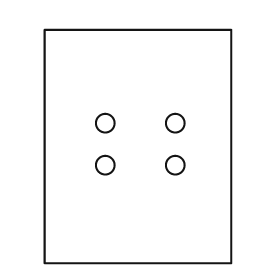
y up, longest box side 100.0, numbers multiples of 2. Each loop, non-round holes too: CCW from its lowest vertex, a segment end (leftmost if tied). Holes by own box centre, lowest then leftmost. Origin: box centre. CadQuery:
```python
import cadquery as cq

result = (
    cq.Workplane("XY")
    .moveTo(-40.0, -50.0)
    .lineTo(40.0, -50.0)
    .lineTo(40.0, 50.0)
    .lineTo(-40.0, 50.0)
    .close()
    .moveTo(-14.0, -8.0)
    .circle(4.0)
    .moveTo(16.0, -8.0)
    .circle(4.0)
    .moveTo(-14.0, 10.0)
    .circle(4.0)
    .moveTo(16.0, 10.0)
    .circle(4.0)
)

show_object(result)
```